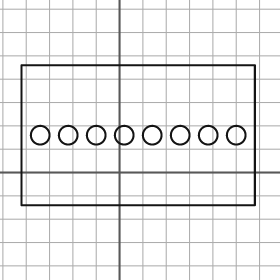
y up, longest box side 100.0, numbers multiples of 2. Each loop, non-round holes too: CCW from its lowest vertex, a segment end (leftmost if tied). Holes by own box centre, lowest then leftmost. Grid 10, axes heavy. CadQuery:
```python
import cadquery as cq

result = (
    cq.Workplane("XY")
    .moveTo(-42.0, -14.0)
    .lineTo(58.0, -14.0)
    .lineTo(58.0, 46.0)
    .lineTo(-42.0, 46.0)
    .close()
    .moveTo(-34.0, 16.0)
    .circle(4.0)
    .moveTo(-22.0, 16.0)
    .circle(4.0)
    .moveTo(-10.0, 16.0)
    .circle(4.0)
    .moveTo(2.0, 16.0)
    .circle(4.0)
    .moveTo(14.0, 16.0)
    .circle(4.0)
    .moveTo(26.0, 16.0)
    .circle(4.0)
    .moveTo(38.0, 16.0)
    .circle(4.0)
    .moveTo(50.0, 16.0)
    .circle(4.0)
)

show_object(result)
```